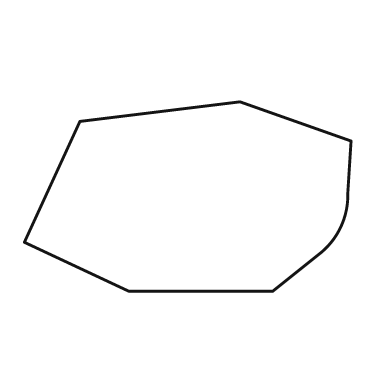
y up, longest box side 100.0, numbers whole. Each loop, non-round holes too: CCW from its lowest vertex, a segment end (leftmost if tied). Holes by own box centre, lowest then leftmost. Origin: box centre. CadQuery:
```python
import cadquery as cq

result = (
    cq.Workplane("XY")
    .moveTo(-18.0, -29.0)
    .lineTo(26.0, -29.0)
    .lineTo(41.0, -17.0)
    .threePointArc((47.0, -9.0), (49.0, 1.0))
    .lineTo(50.0, 17.0)
    .lineTo(16.0, 29.0)
    .lineTo(-33.0, 23.0)
    .lineTo(-50.0, -14.0)
    .close()
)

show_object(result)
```